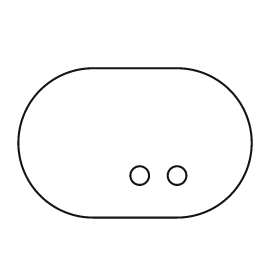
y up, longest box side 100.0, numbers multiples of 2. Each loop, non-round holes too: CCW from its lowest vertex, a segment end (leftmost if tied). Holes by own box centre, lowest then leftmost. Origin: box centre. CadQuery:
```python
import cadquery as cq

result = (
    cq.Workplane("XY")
    .moveTo(-18.0, -32.0)
    .lineTo(18.0, -32.0)
    .threePointArc((50.0, 0.0), (18.0, 32.0))
    .lineTo(-18.0, 32.0)
    .threePointArc((-50.0, 0.0), (-18.0, -32.0))
    .close()
    .moveTo(2.0, -14.0)
    .circle(4.0)
    .moveTo(18.0, -14.0)
    .circle(4.0)
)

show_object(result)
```